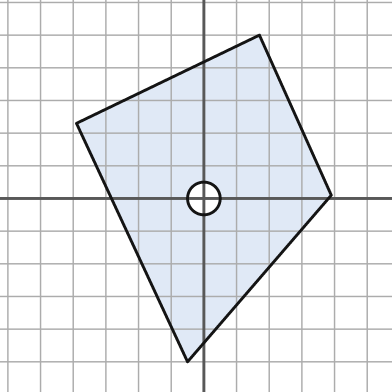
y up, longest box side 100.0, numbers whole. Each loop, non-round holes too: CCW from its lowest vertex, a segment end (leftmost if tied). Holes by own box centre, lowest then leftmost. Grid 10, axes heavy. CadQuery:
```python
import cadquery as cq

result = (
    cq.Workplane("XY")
    .moveTo(-5.0, -50.0)
    .lineTo(39.0, 1.0)
    .lineTo(17.0, 50.0)
    .lineTo(-39.0, 23.0)
    .close()
    .moveTo(0.0, 0.0)
    .circle(5.0)
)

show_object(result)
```